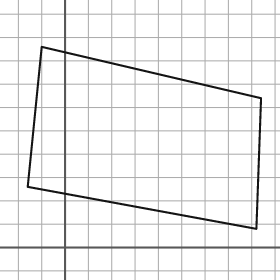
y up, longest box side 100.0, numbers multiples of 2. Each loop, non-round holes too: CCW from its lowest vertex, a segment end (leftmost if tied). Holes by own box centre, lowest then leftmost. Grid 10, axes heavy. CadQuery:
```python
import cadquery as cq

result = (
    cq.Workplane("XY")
    .moveTo(82.0, 8.0)
    .lineTo(84.0, 64.0)
    .lineTo(-10.0, 86.0)
    .lineTo(-16.0, 26.0)
    .close()
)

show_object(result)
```